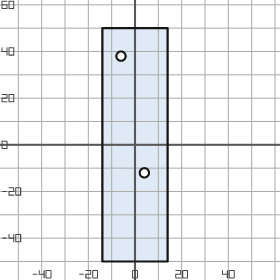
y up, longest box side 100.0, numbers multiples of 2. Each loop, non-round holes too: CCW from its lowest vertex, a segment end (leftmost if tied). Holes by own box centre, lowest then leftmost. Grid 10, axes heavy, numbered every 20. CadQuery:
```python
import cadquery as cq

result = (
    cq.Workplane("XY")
    .moveTo(-14.0, -50.0)
    .lineTo(14.0, -50.0)
    .lineTo(14.0, 50.0)
    .lineTo(-14.0, 50.0)
    .close()
    .moveTo(4.0, -12.0)
    .circle(2.0)
    .moveTo(-6.0, 38.0)
    .circle(2.0)
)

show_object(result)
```